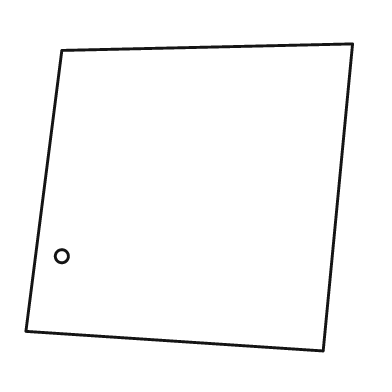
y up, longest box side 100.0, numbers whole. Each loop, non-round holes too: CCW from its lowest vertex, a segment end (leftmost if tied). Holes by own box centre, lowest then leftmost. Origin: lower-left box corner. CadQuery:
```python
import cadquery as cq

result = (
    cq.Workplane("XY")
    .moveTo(91.0, 0.0)
    .lineTo(100.0, 94.0)
    .lineTo(11.0, 92.0)
    .lineTo(0.0, 6.0)
    .close()
    .moveTo(11.0, 29.0)
    .circle(2.0)
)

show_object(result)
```